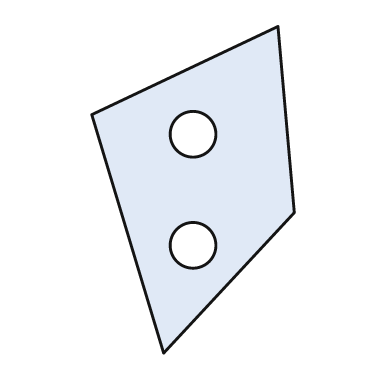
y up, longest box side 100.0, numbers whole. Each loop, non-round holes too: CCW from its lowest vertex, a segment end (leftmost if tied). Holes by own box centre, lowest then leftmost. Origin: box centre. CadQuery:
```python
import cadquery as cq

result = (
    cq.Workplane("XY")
    .moveTo(-9.0, -50.0)
    .lineTo(31.0, -7.0)
    .lineTo(26.0, 50.0)
    .lineTo(-31.0, 23.0)
    .close()
    .moveTo(0.0, -17.0)
    .circle(7.0)
    .moveTo(0.0, 17.0)
    .circle(7.0)
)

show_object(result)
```